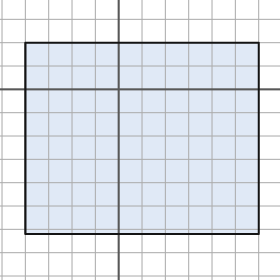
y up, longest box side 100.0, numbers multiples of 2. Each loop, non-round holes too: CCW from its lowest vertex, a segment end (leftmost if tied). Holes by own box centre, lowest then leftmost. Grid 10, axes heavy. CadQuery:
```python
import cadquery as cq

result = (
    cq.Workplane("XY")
    .moveTo(-40.0, -62.0)
    .lineTo(60.0, -62.0)
    .lineTo(60.0, 20.0)
    .lineTo(-40.0, 20.0)
    .close()
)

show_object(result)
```